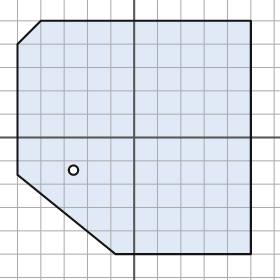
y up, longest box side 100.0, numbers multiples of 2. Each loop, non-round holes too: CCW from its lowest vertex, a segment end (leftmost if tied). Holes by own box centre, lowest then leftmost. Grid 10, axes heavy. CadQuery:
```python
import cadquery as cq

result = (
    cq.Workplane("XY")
    .moveTo(-8.0, -50.0)
    .lineTo(50.0, -50.0)
    .lineTo(50.0, 50.0)
    .lineTo(-40.0, 50.0)
    .lineTo(-50.0, 40.0)
    .lineTo(-50.0, -16.0)
    .close()
    .moveTo(-26.0, -14.0)
    .circle(2.0)
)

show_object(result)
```